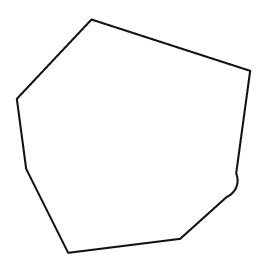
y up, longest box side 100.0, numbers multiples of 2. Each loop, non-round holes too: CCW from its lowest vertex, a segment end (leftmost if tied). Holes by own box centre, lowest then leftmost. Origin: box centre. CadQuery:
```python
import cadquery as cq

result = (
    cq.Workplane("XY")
    .moveTo(-28.0, -50.0)
    .lineTo(20.0, -44.0)
    .lineTo(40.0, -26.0)
    .threePointArc((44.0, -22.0), (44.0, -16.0))
    .lineTo(50.0, 28.0)
    .lineTo(-18.0, 50.0)
    .lineTo(-50.0, 16.0)
    .lineTo(-46.0, -14.0)
    .close()
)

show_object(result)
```